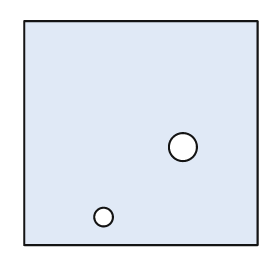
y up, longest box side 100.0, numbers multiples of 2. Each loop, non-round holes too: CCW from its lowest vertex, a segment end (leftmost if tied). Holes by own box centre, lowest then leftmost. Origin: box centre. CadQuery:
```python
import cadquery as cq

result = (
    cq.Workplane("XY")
    .moveTo(-50.0, -48.0)
    .lineTo(50.0, -48.0)
    .lineTo(50.0, 48.0)
    .lineTo(-50.0, 48.0)
    .close()
    .moveTo(-16.0, -36.0)
    .circle(4.0)
    .moveTo(18.0, -6.0)
    .circle(6.0)
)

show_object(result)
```